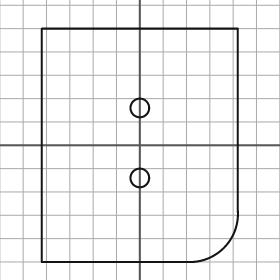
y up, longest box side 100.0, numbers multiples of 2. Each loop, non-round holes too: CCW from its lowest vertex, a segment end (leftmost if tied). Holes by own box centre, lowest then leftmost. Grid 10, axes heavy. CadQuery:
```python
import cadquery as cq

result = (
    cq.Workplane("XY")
    .moveTo(-42.0, -50.0)
    .lineTo(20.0, -50.0)
    .threePointArc((36.0, -44.0), (42.0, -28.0))
    .lineTo(42.0, 50.0)
    .lineTo(-42.0, 50.0)
    .close()
    .moveTo(0.0, -14.0)
    .circle(4.0)
    .moveTo(0.0, 16.0)
    .circle(4.0)
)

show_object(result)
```